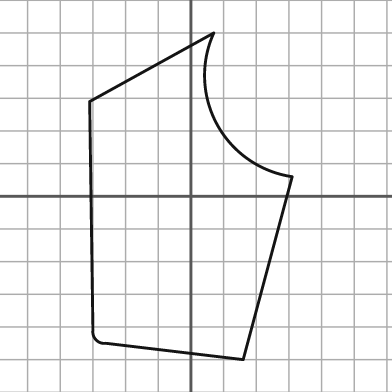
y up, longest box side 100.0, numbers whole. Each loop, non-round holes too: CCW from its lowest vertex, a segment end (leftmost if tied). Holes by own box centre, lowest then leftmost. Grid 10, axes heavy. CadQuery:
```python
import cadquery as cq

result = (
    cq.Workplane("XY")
    .moveTo(16.0, -50.0)
    .lineTo(31.0, 6.0)
    .threePointArc((8.0, 22.0), (7.0, 50.0))
    .lineTo(-31.0, 29.0)
    .lineTo(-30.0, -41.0)
    .threePointArc((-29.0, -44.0), (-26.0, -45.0))
    .close()
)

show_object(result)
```